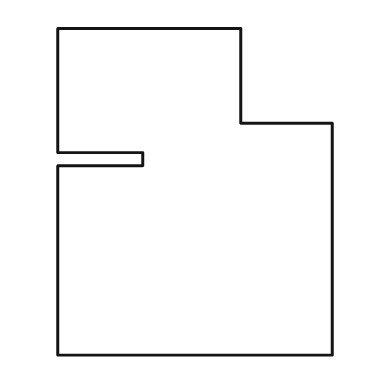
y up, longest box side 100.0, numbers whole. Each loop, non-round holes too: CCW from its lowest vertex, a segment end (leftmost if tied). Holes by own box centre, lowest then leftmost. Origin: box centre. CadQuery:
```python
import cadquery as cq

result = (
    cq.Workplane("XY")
    .moveTo(-42.0, -50.0)
    .lineTo(42.0, -50.0)
    .lineTo(42.0, 21.0)
    .lineTo(14.0, 21.0)
    .lineTo(14.0, 50.0)
    .lineTo(-42.0, 50.0)
    .lineTo(-42.0, 12.0)
    .lineTo(-16.0, 12.0)
    .lineTo(-16.0, 8.0)
    .lineTo(-42.0, 8.0)
    .close()
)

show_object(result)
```